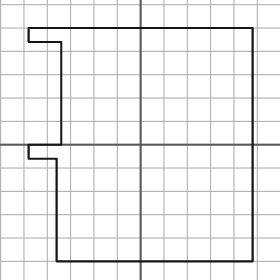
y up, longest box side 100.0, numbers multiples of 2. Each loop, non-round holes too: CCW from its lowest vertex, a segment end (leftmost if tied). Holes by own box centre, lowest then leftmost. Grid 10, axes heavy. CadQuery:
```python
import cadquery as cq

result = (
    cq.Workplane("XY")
    .moveTo(-36.0, -50.0)
    .lineTo(48.0, -50.0)
    .lineTo(48.0, 50.0)
    .lineTo(-48.0, 50.0)
    .lineTo(-48.0, 44.0)
    .lineTo(-34.0, 44.0)
    .lineTo(-34.0, 0.0)
    .lineTo(-48.0, 0.0)
    .lineTo(-48.0, -6.0)
    .lineTo(-36.0, -6.0)
    .close()
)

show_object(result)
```